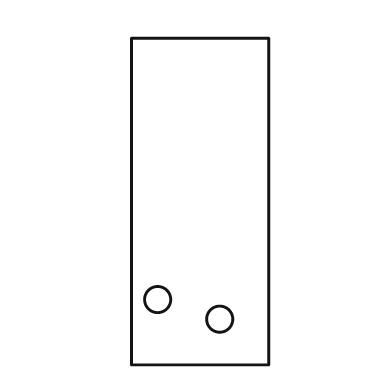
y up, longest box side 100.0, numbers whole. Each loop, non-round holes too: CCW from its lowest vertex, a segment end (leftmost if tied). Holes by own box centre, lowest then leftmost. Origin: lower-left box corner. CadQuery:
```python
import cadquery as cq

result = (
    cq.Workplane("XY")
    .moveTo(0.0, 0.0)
    .lineTo(42.0, 0.0)
    .lineTo(42.0, 100.0)
    .lineTo(0.0, 100.0)
    .close()
    .moveTo(27.0, 14.0)
    .circle(4.0)
    .moveTo(8.0, 20.0)
    .circle(4.0)
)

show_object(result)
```